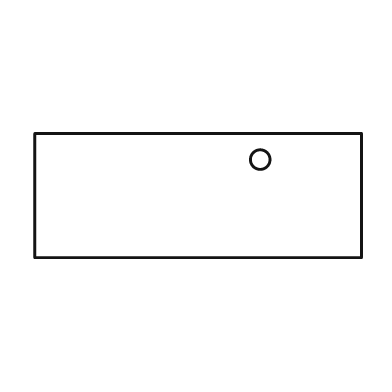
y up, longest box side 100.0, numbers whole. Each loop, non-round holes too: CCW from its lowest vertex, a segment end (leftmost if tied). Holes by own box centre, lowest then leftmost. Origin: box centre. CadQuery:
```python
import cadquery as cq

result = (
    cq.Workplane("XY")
    .moveTo(-50.0, -19.0)
    .lineTo(50.0, -19.0)
    .lineTo(50.0, 19.0)
    .lineTo(-50.0, 19.0)
    .close()
    .moveTo(19.0, 11.0)
    .circle(3.0)
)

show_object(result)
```